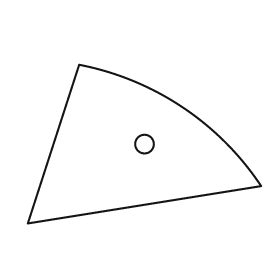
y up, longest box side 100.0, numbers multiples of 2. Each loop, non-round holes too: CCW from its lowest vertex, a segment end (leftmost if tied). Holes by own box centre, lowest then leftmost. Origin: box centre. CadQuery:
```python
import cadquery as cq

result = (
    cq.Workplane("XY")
    .moveTo(-50.0, -34.0)
    .lineTo(50.0, -18.0)
    .threePointArc((16.0, 16.0), (-28.0, 34.0))
    .close()
    .moveTo(0.0, 0.0)
    .circle(4.0)
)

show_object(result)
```